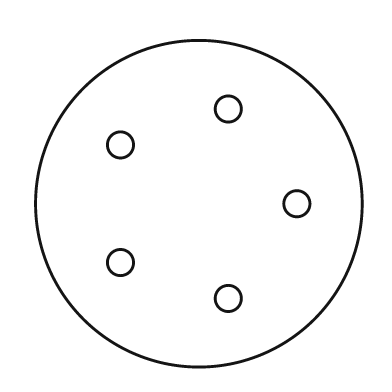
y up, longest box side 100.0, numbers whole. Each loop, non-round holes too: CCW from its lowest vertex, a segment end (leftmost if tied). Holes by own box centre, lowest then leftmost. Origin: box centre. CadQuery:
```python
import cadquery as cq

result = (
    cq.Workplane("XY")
    .moveTo(0.0, 0.0)
    .circle(50.0)
    .moveTo(9.0, -29.0)
    .circle(4.0)
    .moveTo(-24.0, -18.0)
    .circle(4.0)
    .moveTo(30.0, 0.0)
    .circle(4.0)
    .moveTo(-24.0, 18.0)
    .circle(4.0)
    .moveTo(9.0, 29.0)
    .circle(4.0)
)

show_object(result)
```